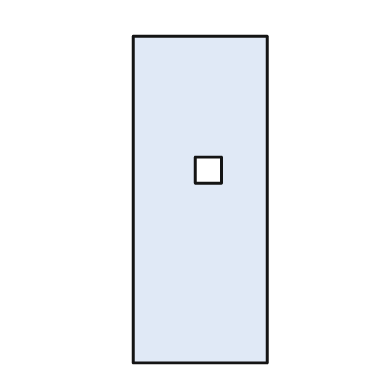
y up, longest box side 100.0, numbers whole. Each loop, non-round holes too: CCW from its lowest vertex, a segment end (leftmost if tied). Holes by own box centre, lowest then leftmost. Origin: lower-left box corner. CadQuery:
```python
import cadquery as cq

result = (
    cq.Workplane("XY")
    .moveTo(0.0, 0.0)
    .lineTo(41.0, 0.0)
    .lineTo(41.0, 100.0)
    .lineTo(0.0, 100.0)
    .close()
    .moveTo(19.0, 55.0)
    .lineTo(27.0, 55.0)
    .lineTo(27.0, 63.0)
    .lineTo(19.0, 63.0)
    .close()
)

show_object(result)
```